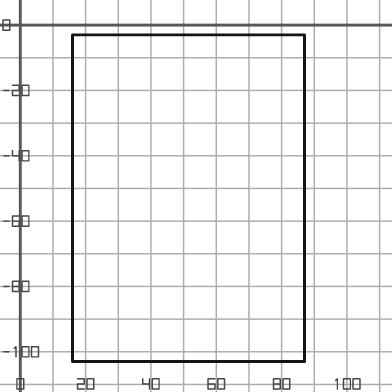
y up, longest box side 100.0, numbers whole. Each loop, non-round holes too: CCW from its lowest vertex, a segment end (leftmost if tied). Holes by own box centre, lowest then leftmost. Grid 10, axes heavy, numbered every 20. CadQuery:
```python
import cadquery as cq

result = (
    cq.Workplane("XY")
    .moveTo(16.0, -103.0)
    .lineTo(87.0, -103.0)
    .lineTo(87.0, -3.0)
    .lineTo(16.0, -3.0)
    .close()
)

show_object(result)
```